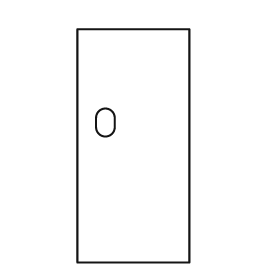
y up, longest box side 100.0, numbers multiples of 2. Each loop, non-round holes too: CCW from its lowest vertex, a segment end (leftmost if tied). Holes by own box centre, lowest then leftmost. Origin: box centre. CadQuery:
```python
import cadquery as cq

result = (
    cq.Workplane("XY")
    .moveTo(-24.0, -50.0)
    .lineTo(24.0, -50.0)
    .lineTo(24.0, 50.0)
    .lineTo(-24.0, 50.0)
    .close()
    .moveTo(-16.0, 8.0)
    .threePointArc((-12.0, 4.0), (-8.0, 8.0))
    .lineTo(-8.0, 12.0)
    .threePointArc((-12.0, 16.0), (-16.0, 12.0))
    .close()
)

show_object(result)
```